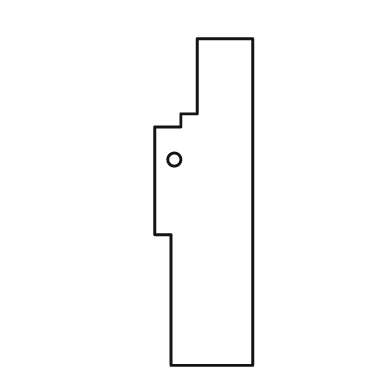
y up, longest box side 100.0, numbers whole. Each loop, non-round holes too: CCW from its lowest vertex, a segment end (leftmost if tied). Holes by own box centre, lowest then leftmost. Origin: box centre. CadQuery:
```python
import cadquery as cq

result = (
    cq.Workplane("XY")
    .moveTo(-10.0, -50.0)
    .lineTo(15.0, -50.0)
    .lineTo(15.0, 50.0)
    .lineTo(-2.0, 50.0)
    .lineTo(-2.0, 27.0)
    .lineTo(-7.0, 27.0)
    .lineTo(-7.0, 23.0)
    .lineTo(-15.0, 23.0)
    .lineTo(-15.0, -10.0)
    .lineTo(-10.0, -10.0)
    .close()
    .moveTo(-9.0, 13.0)
    .circle(2.0)
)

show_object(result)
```